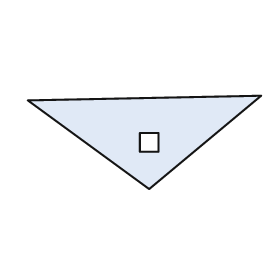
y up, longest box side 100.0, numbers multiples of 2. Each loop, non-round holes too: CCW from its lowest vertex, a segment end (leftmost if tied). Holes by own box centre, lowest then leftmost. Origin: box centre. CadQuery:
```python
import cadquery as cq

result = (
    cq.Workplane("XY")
    .moveTo(2.0, -20.0)
    .lineTo(50.0, 20.0)
    .lineTo(-50.0, 18.0)
    .close()
    .moveTo(-2.0, -4.0)
    .lineTo(6.0, -4.0)
    .lineTo(6.0, 4.0)
    .lineTo(-2.0, 4.0)
    .close()
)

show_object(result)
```